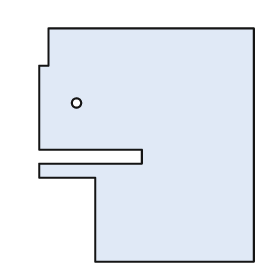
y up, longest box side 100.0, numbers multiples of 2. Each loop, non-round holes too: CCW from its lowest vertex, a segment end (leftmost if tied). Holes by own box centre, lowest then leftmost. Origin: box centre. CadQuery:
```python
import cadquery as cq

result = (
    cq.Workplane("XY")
    .moveTo(-22.0, -50.0)
    .lineTo(46.0, -50.0)
    .lineTo(46.0, 50.0)
    .lineTo(-42.0, 50.0)
    .lineTo(-42.0, 34.0)
    .lineTo(-46.0, 34.0)
    .lineTo(-46.0, -2.0)
    .lineTo(-2.0, -2.0)
    .lineTo(-2.0, -8.0)
    .lineTo(-46.0, -8.0)
    .lineTo(-46.0, -14.0)
    .lineTo(-22.0, -14.0)
    .close()
    .moveTo(-30.0, 18.0)
    .circle(2.0)
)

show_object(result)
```